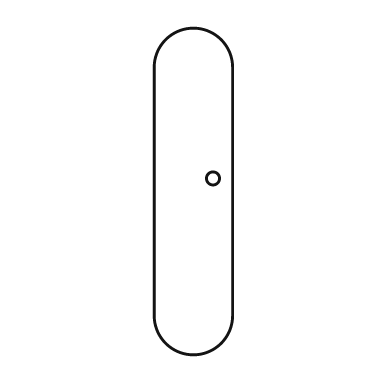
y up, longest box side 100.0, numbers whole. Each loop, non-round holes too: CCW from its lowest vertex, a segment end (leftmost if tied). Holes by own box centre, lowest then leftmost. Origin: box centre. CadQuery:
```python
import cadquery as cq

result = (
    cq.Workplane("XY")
    .moveTo(-12.0, -38.0)
    .threePointArc((0.0, -50.0), (12.0, -38.0))
    .lineTo(12.0, 38.0)
    .threePointArc((0.0, 50.0), (-12.0, 38.0))
    .close()
    .moveTo(6.0, 4.0)
    .circle(2.0)
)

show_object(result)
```